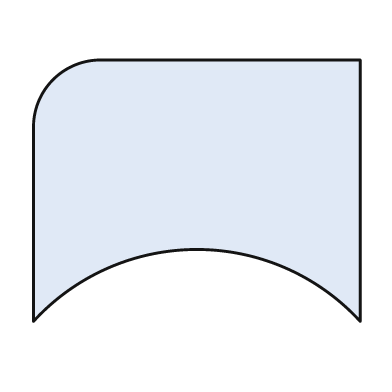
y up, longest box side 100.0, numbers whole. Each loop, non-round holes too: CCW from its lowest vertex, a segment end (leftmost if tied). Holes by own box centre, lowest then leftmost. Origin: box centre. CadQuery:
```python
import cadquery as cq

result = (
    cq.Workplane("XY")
    .moveTo(-50.0, -40.0)
    .threePointArc((0.0, -18.0), (50.0, -40.0))
    .lineTo(50.0, 40.0)
    .lineTo(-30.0, 40.0)
    .threePointArc((-44.0, 34.0), (-50.0, 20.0))
    .close()
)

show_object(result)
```